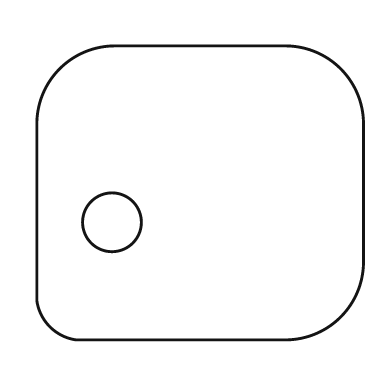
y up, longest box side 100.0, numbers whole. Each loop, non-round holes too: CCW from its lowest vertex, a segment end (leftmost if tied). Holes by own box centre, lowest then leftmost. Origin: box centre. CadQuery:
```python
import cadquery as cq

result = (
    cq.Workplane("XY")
    .moveTo(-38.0, -45.0)
    .lineTo(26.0, -45.0)
    .threePointArc((43.0, -38.0), (50.0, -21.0))
    .lineTo(50.0, 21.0)
    .threePointArc((43.0, 38.0), (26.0, 45.0))
    .lineTo(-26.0, 45.0)
    .threePointArc((-43.0, 38.0), (-50.0, 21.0))
    .lineTo(-50.0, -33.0)
    .threePointArc((-46.0, -41.0), (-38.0, -45.0))
    .close()
    .moveTo(-27.0, -9.0)
    .circle(9.0)
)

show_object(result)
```